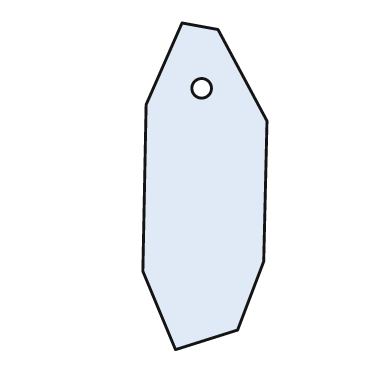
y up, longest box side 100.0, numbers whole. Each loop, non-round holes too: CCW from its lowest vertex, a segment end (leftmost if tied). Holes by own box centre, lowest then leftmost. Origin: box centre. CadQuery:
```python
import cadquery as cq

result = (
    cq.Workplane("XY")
    .moveTo(-9.0, -50.0)
    .lineTo(10.0, -44.0)
    .lineTo(18.0, -23.0)
    .lineTo(19.0, 20.0)
    .lineTo(4.0, 48.0)
    .lineTo(-7.0, 50.0)
    .lineTo(-18.0, 25.0)
    .lineTo(-19.0, -26.0)
    .close()
    .moveTo(-1.0, 30.0)
    .circle(3.0)
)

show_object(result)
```